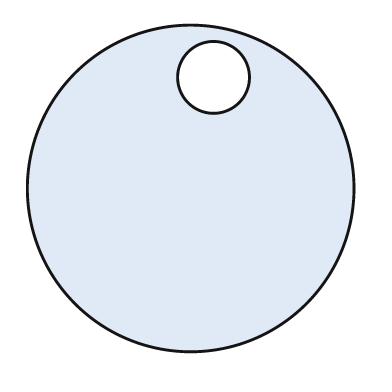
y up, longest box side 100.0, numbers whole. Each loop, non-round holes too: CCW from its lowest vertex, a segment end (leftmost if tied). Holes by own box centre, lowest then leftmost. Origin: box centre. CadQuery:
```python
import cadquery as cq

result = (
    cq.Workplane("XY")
    .moveTo(0.0, 0.0)
    .circle(50.0)
    .moveTo(7.0, 34.0)
    .circle(11.0)
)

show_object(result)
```